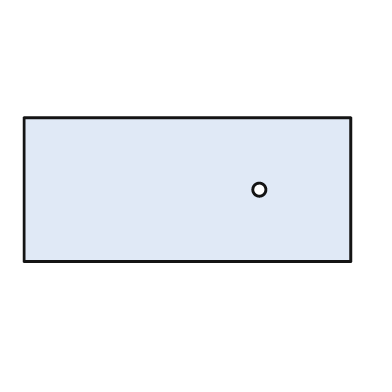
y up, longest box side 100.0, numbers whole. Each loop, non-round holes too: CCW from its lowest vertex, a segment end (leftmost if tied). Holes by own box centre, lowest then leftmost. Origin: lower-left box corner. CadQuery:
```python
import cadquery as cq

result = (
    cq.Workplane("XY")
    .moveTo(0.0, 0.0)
    .lineTo(100.0, 0.0)
    .lineTo(100.0, 44.0)
    .lineTo(0.0, 44.0)
    .close()
    .moveTo(72.0, 22.0)
    .circle(2.0)
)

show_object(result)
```